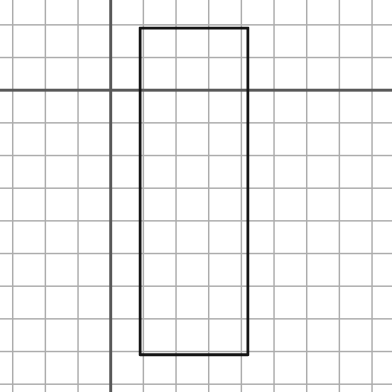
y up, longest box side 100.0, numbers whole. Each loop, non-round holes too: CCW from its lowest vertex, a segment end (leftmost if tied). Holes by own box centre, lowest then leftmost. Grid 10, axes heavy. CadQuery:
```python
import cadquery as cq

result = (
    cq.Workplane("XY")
    .moveTo(9.0, -81.0)
    .lineTo(42.0, -81.0)
    .lineTo(42.0, 19.0)
    .lineTo(9.0, 19.0)
    .close()
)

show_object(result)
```